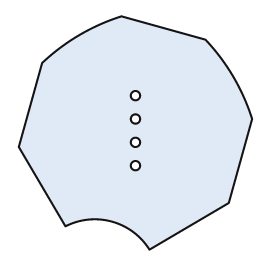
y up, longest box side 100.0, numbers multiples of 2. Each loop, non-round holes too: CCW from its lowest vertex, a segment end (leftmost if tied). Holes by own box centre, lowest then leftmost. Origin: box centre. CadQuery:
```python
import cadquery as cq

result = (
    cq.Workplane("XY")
    .moveTo(6.0, -50.0)
    .lineTo(40.0, -30.0)
    .lineTo(50.0, 6.0)
    .threePointArc((42.0, 24.0), (30.0, 40.0))
    .lineTo(-6.0, 50.0)
    .threePointArc((-24.0, 42.0), (-40.0, 30.0))
    .lineTo(-50.0, -6.0)
    .lineTo(-30.0, -40.0)
    .threePointArc((-10.0, -38.0), (6.0, -50.0))
    .close()
    .moveTo(0.0, -14.0)
    .circle(2.0)
    .moveTo(0.0, -4.0)
    .circle(2.0)
    .moveTo(0.0, 6.0)
    .circle(2.0)
    .moveTo(0.0, 16.0)
    .circle(2.0)
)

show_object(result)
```